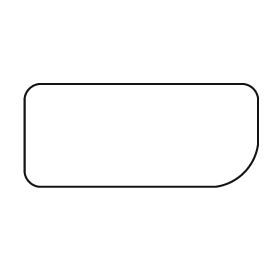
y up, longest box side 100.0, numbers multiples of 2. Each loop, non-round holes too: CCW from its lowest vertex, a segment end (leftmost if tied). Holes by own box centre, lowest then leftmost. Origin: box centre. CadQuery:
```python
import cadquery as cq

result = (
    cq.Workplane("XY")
    .moveTo(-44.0, -22.0)
    .lineTo(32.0, -22.0)
    .threePointArc((44.0, -16.0), (50.0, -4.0))
    .lineTo(50.0, 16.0)
    .threePointArc((48.0, 20.0), (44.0, 22.0))
    .lineTo(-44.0, 22.0)
    .threePointArc((-48.0, 20.0), (-50.0, 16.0))
    .lineTo(-50.0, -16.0)
    .threePointArc((-48.0, -20.0), (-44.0, -22.0))
    .close()
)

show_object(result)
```